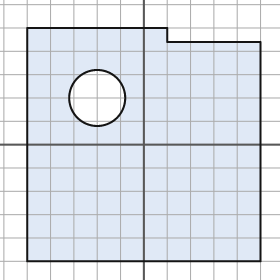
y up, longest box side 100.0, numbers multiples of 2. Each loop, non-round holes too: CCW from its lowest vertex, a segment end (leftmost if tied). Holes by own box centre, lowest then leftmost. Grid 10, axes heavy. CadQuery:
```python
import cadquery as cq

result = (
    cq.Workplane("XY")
    .moveTo(-50.0, -50.0)
    .lineTo(50.0, -50.0)
    .lineTo(50.0, 44.0)
    .lineTo(10.0, 44.0)
    .lineTo(10.0, 50.0)
    .lineTo(-50.0, 50.0)
    .close()
    .moveTo(-20.0, 20.0)
    .circle(12.0)
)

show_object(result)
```